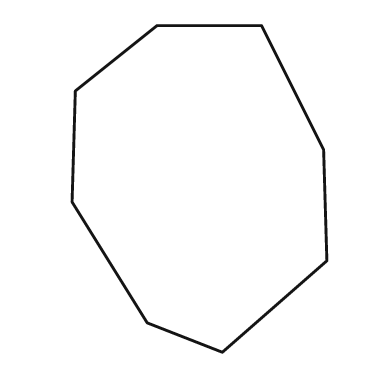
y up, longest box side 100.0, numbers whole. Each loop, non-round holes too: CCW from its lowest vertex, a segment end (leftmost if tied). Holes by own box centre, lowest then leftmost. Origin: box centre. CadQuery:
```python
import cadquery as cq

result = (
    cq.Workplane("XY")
    .moveTo(7.0, -50.0)
    .lineTo(39.0, -22.0)
    .lineTo(38.0, 12.0)
    .lineTo(19.0, 50.0)
    .lineTo(-13.0, 50.0)
    .lineTo(-38.0, 30.0)
    .lineTo(-39.0, -4.0)
    .lineTo(-16.0, -41.0)
    .close()
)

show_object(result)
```